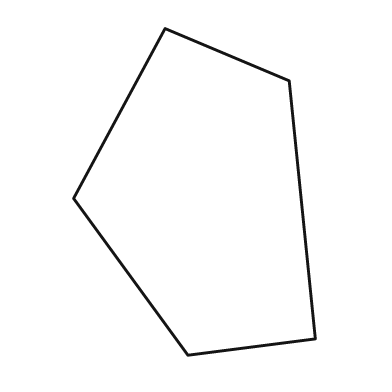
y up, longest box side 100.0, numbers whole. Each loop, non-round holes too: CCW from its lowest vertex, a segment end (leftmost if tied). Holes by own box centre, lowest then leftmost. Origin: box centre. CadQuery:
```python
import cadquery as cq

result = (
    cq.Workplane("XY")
    .moveTo(-2.0, -50.0)
    .lineTo(37.0, -45.0)
    .lineTo(29.0, 34.0)
    .lineTo(-9.0, 50.0)
    .lineTo(-37.0, -2.0)
    .close()
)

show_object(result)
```